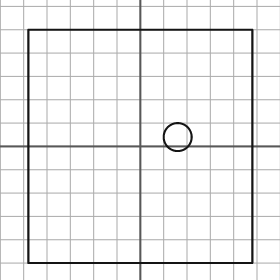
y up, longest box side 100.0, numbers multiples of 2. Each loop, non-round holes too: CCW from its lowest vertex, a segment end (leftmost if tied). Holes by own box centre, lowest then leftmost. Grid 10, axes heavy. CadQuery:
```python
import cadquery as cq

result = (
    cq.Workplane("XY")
    .moveTo(-48.0, -50.0)
    .lineTo(48.0, -50.0)
    .lineTo(48.0, 50.0)
    .lineTo(-48.0, 50.0)
    .close()
    .moveTo(16.0, 4.0)
    .circle(6.0)
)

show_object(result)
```